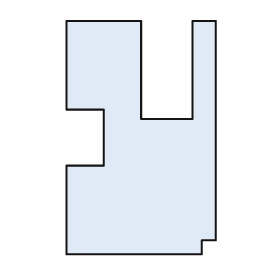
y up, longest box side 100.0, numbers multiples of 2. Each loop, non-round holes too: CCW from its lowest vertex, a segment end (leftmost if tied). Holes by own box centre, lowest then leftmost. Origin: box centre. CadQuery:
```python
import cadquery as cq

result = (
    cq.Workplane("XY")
    .moveTo(-32.0, -50.0)
    .lineTo(26.0, -50.0)
    .lineTo(26.0, -44.0)
    .lineTo(32.0, -44.0)
    .lineTo(32.0, 50.0)
    .lineTo(22.0, 50.0)
    .lineTo(22.0, 8.0)
    .lineTo(0.0, 8.0)
    .lineTo(0.0, 50.0)
    .lineTo(-32.0, 50.0)
    .lineTo(-32.0, 12.0)
    .lineTo(-16.0, 12.0)
    .lineTo(-16.0, -12.0)
    .lineTo(-32.0, -12.0)
    .close()
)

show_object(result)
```